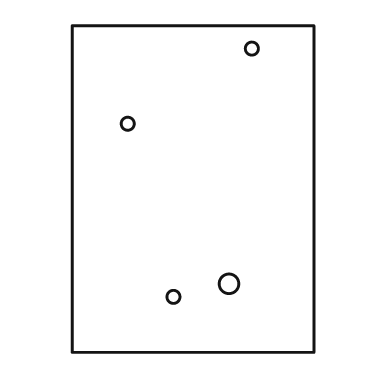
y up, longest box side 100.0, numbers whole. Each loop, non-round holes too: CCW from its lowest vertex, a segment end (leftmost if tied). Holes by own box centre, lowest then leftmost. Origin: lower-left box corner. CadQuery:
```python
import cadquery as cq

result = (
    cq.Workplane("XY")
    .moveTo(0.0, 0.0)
    .lineTo(74.0, 0.0)
    .lineTo(74.0, 100.0)
    .lineTo(0.0, 100.0)
    .close()
    .moveTo(31.0, 17.0)
    .circle(2.0)
    .moveTo(48.0, 21.0)
    .circle(3.0)
    .moveTo(17.0, 70.0)
    .circle(2.0)
    .moveTo(55.0, 93.0)
    .circle(2.0)
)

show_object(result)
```